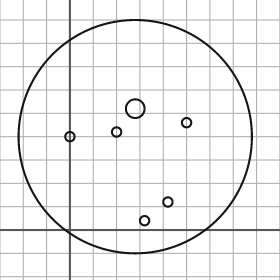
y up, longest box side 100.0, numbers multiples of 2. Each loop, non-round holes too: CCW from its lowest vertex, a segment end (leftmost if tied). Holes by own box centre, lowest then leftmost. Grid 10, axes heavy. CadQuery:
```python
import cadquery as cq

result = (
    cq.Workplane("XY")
    .moveTo(28.0, 40.0)
    .circle(50.0)
    .moveTo(32.0, 4.0)
    .circle(2.0)
    .moveTo(42.0, 12.0)
    .circle(2.0)
    .moveTo(0.0, 40.0)
    .circle(2.0)
    .moveTo(20.0, 42.0)
    .circle(2.0)
    .moveTo(50.0, 46.0)
    .circle(2.0)
    .moveTo(28.0, 52.0)
    .circle(4.0)
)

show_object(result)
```